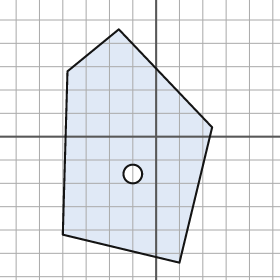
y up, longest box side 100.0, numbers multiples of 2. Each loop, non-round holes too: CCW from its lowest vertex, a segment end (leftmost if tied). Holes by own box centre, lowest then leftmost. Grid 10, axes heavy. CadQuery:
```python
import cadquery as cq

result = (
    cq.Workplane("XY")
    .moveTo(10.0, -54.0)
    .lineTo(24.0, 4.0)
    .lineTo(-16.0, 46.0)
    .lineTo(-38.0, 28.0)
    .lineTo(-40.0, -42.0)
    .close()
    .moveTo(-10.0, -16.0)
    .circle(4.0)
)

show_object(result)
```